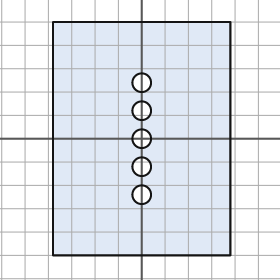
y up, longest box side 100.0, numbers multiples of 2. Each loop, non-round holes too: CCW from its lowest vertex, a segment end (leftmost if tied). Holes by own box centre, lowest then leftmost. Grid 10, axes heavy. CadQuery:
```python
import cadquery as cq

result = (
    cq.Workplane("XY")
    .moveTo(-38.0, -50.0)
    .lineTo(38.0, -50.0)
    .lineTo(38.0, 50.0)
    .lineTo(-38.0, 50.0)
    .close()
    .moveTo(0.0, -24.0)
    .circle(4.0)
    .moveTo(0.0, -12.0)
    .circle(4.0)
    .moveTo(0.0, 0.0)
    .circle(4.0)
    .moveTo(0.0, 12.0)
    .circle(4.0)
    .moveTo(0.0, 24.0)
    .circle(4.0)
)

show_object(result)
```